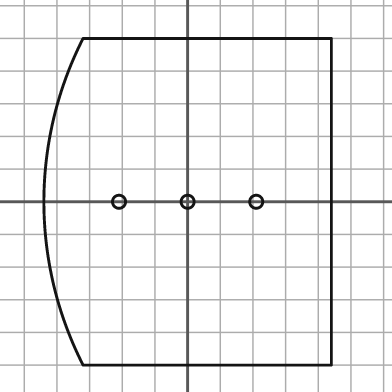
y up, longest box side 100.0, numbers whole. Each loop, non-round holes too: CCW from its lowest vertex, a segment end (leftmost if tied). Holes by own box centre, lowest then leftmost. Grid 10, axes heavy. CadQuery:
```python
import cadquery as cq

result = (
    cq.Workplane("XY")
    .moveTo(-32.0, -50.0)
    .lineTo(44.0, -50.0)
    .lineTo(44.0, 50.0)
    .lineTo(-32.0, 50.0)
    .threePointArc((-44.0, 0.0), (-32.0, -50.0))
    .close()
    .moveTo(-21.0, 0.0)
    .circle(2.0)
    .moveTo(0.0, 0.0)
    .circle(2.0)
    .moveTo(21.0, 0.0)
    .circle(2.0)
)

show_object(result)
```